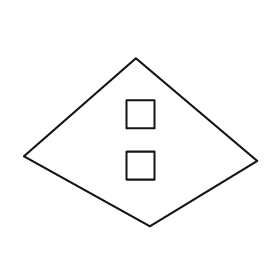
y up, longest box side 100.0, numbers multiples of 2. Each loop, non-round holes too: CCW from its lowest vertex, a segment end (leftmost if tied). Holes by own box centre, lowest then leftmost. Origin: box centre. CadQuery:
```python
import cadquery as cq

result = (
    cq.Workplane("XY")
    .moveTo(4.0, -36.0)
    .lineTo(50.0, -8.0)
    .lineTo(-2.0, 36.0)
    .lineTo(-50.0, -6.0)
    .close()
    .moveTo(-6.0, -16.0)
    .lineTo(6.0, -16.0)
    .lineTo(6.0, -4.0)
    .lineTo(-6.0, -4.0)
    .close()
    .moveTo(-6.0, 6.0)
    .lineTo(6.0, 6.0)
    .lineTo(6.0, 18.0)
    .lineTo(-6.0, 18.0)
    .close()
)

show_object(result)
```